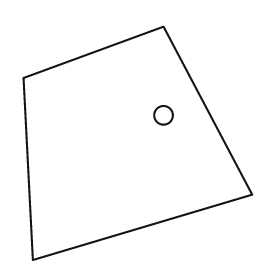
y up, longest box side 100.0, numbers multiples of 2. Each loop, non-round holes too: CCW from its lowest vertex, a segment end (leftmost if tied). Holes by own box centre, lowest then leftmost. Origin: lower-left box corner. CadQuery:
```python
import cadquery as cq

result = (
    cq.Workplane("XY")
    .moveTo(4.0, 0.0)
    .lineTo(98.0, 28.0)
    .lineTo(60.0, 100.0)
    .lineTo(0.0, 78.0)
    .close()
    .moveTo(60.0, 62.0)
    .circle(4.0)
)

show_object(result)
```